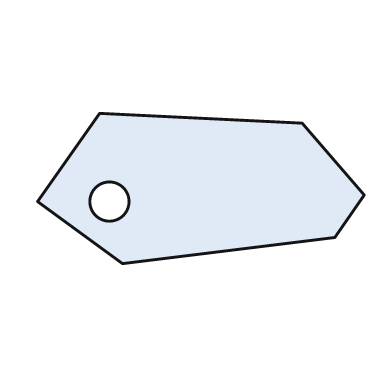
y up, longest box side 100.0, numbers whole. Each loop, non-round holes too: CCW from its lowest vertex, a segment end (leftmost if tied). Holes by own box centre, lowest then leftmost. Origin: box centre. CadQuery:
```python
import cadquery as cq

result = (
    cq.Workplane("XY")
    .moveTo(-24.0, -23.0)
    .lineTo(41.0, -15.0)
    .lineTo(50.0, -2.0)
    .lineTo(31.0, 20.0)
    .lineTo(-31.0, 23.0)
    .lineTo(-50.0, -4.0)
    .close()
    .moveTo(-28.0, -4.0)
    .circle(6.0)
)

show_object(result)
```